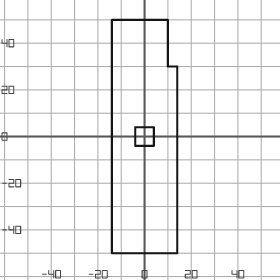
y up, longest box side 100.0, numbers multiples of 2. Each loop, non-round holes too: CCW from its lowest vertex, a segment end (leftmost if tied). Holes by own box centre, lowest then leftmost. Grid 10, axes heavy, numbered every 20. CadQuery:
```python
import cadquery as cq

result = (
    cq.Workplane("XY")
    .moveTo(-14.0, -50.0)
    .lineTo(14.0, -50.0)
    .lineTo(14.0, 30.0)
    .lineTo(10.0, 30.0)
    .lineTo(10.0, 50.0)
    .lineTo(-14.0, 50.0)
    .close()
    .moveTo(-4.0, -4.0)
    .lineTo(4.0, -4.0)
    .lineTo(4.0, 4.0)
    .lineTo(-4.0, 4.0)
    .close()
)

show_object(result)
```